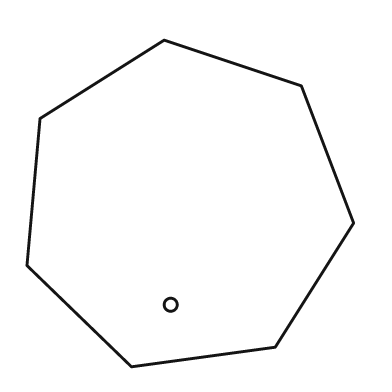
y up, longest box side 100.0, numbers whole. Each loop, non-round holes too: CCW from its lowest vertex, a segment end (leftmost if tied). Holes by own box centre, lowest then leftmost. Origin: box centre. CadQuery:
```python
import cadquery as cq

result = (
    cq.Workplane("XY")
    .moveTo(-18.0, -50.0)
    .lineTo(26.0, -44.0)
    .lineTo(50.0, -6.0)
    .lineTo(34.0, 36.0)
    .lineTo(-8.0, 50.0)
    .lineTo(-46.0, 26.0)
    .lineTo(-50.0, -19.0)
    .close()
    .moveTo(-6.0, -31.0)
    .circle(2.0)
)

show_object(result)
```